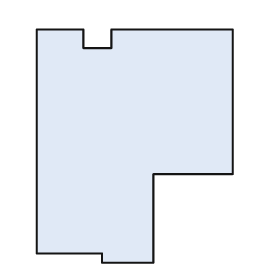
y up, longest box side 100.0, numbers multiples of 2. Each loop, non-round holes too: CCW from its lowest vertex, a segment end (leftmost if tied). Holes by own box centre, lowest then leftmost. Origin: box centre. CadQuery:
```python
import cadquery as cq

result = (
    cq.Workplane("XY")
    .moveTo(-14.0, -50.0)
    .lineTo(8.0, -50.0)
    .lineTo(8.0, -12.0)
    .lineTo(42.0, -12.0)
    .lineTo(42.0, 50.0)
    .lineTo(-10.0, 50.0)
    .lineTo(-10.0, 42.0)
    .lineTo(-22.0, 42.0)
    .lineTo(-22.0, 50.0)
    .lineTo(-42.0, 50.0)
    .lineTo(-42.0, -46.0)
    .lineTo(-14.0, -46.0)
    .close()
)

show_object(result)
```